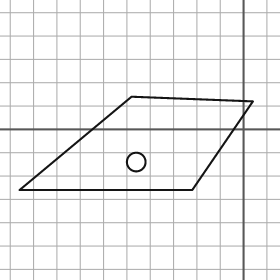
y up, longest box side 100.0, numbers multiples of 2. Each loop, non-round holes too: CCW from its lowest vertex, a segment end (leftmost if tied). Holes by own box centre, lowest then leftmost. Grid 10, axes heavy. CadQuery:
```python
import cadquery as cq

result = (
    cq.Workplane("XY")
    .moveTo(-96.0, -26.0)
    .lineTo(-22.0, -26.0)
    .lineTo(4.0, 12.0)
    .lineTo(-48.0, 14.0)
    .close()
    .moveTo(-46.0, -14.0)
    .circle(4.0)
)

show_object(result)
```